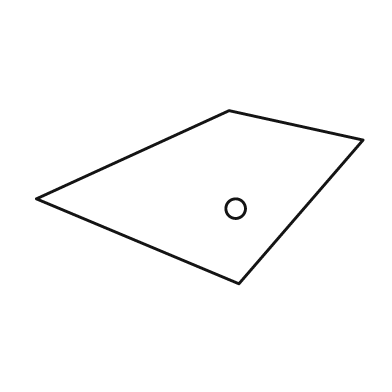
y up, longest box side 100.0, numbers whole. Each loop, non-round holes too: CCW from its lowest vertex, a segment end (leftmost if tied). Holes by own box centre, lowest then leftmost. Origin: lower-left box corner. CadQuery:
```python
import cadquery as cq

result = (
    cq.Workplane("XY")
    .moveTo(62.0, 0.0)
    .lineTo(100.0, 44.0)
    .lineTo(59.0, 53.0)
    .lineTo(0.0, 26.0)
    .close()
    .moveTo(61.0, 23.0)
    .circle(3.0)
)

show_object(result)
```